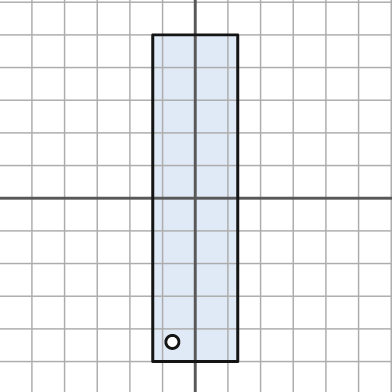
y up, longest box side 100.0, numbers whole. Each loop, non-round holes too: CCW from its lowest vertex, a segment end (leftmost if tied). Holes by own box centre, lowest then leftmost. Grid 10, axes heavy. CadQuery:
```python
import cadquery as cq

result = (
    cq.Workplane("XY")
    .moveTo(-13.0, -50.0)
    .lineTo(13.0, -50.0)
    .lineTo(13.0, 50.0)
    .lineTo(-13.0, 50.0)
    .close()
    .moveTo(-7.0, -44.0)
    .circle(2.0)
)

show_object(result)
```